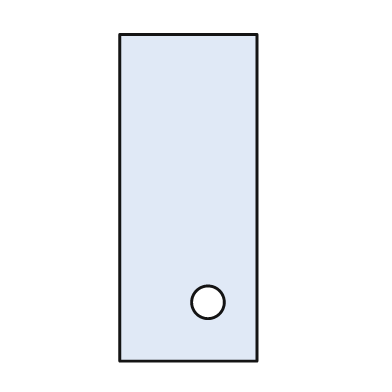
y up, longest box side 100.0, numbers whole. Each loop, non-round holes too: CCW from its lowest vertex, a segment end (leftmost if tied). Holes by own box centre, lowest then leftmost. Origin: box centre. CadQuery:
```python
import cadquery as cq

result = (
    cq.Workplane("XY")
    .moveTo(-21.0, -50.0)
    .lineTo(21.0, -50.0)
    .lineTo(21.0, 50.0)
    .lineTo(-21.0, 50.0)
    .close()
    .moveTo(6.0, -32.0)
    .circle(5.0)
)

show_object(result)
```